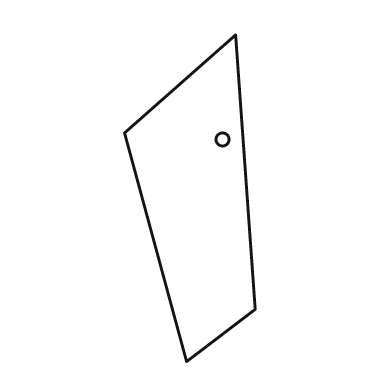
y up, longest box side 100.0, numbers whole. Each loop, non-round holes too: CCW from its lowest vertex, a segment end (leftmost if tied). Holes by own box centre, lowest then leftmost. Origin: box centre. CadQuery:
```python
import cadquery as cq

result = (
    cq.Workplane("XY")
    .moveTo(-1.0, -50.0)
    .lineTo(20.0, -34.0)
    .lineTo(14.0, 50.0)
    .lineTo(-20.0, 20.0)
    .close()
    .moveTo(10.0, 18.0)
    .circle(2.0)
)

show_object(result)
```